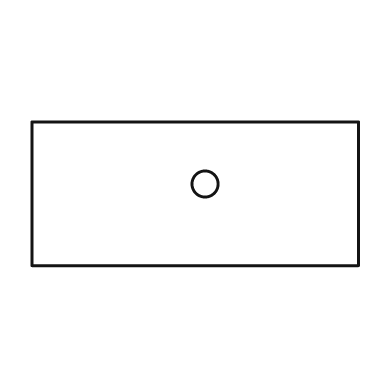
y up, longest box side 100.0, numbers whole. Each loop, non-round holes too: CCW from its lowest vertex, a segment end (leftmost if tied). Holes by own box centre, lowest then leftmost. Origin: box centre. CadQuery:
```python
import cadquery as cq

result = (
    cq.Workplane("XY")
    .moveTo(-50.0, -22.0)
    .lineTo(50.0, -22.0)
    .lineTo(50.0, 22.0)
    .lineTo(-50.0, 22.0)
    .close()
    .moveTo(3.0, 3.0)
    .circle(4.0)
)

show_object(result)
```